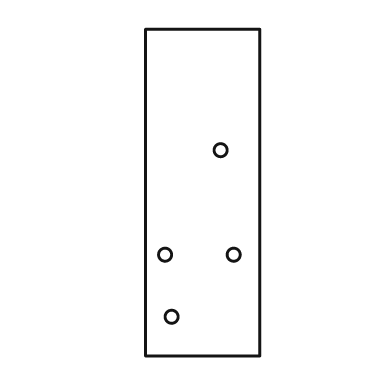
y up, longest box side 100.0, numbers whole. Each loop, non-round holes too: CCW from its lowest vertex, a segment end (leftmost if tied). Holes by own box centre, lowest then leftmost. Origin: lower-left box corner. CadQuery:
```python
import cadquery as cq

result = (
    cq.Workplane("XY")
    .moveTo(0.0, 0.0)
    .lineTo(35.0, 0.0)
    .lineTo(35.0, 100.0)
    .lineTo(0.0, 100.0)
    .close()
    .moveTo(8.0, 12.0)
    .circle(2.0)
    .moveTo(6.0, 31.0)
    .circle(2.0)
    .moveTo(27.0, 31.0)
    .circle(2.0)
    .moveTo(23.0, 63.0)
    .circle(2.0)
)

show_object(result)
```